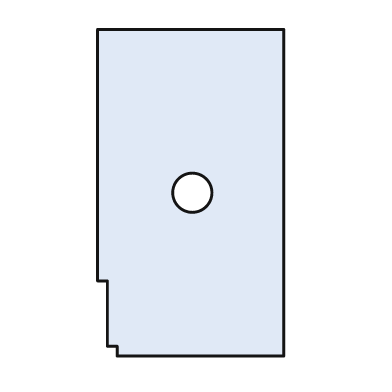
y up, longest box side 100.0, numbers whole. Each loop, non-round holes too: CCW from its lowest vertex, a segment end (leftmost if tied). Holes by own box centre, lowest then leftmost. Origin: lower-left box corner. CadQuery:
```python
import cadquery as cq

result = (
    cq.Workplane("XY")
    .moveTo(6.0, 0.0)
    .lineTo(57.0, 0.0)
    .lineTo(57.0, 100.0)
    .lineTo(0.0, 100.0)
    .lineTo(0.0, 23.0)
    .lineTo(3.0, 23.0)
    .lineTo(3.0, 3.0)
    .lineTo(6.0, 3.0)
    .close()
    .moveTo(29.0, 50.0)
    .circle(6.0)
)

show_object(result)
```